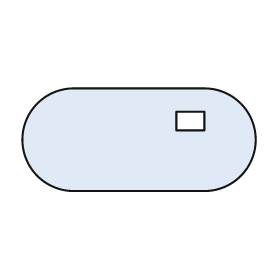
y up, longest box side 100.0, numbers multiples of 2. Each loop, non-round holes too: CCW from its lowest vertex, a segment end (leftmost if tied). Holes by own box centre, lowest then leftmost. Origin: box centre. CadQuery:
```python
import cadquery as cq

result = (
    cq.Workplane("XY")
    .moveTo(-28.0, -22.0)
    .lineTo(28.0, -22.0)
    .threePointArc((50.0, 0.0), (28.0, 22.0))
    .lineTo(-28.0, 22.0)
    .threePointArc((-50.0, 0.0), (-28.0, -22.0))
    .close()
    .moveTo(16.0, 4.0)
    .lineTo(28.0, 4.0)
    .lineTo(28.0, 12.0)
    .lineTo(16.0, 12.0)
    .close()
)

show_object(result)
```